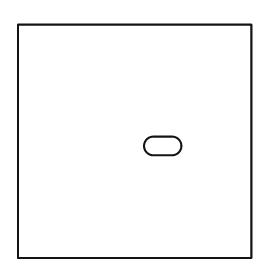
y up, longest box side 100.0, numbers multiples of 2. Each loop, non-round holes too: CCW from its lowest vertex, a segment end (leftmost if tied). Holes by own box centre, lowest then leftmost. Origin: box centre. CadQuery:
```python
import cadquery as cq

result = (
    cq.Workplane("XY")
    .moveTo(-50.0, -50.0)
    .lineTo(50.0, -50.0)
    .lineTo(50.0, 50.0)
    .lineTo(-50.0, 50.0)
    .close()
    .moveTo(8.0, -6.0)
    .lineTo(16.0, -6.0)
    .threePointArc((20.0, -2.0), (16.0, 2.0))
    .lineTo(8.0, 2.0)
    .threePointArc((4.0, -2.0), (8.0, -6.0))
    .close()
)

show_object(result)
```